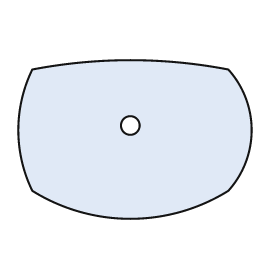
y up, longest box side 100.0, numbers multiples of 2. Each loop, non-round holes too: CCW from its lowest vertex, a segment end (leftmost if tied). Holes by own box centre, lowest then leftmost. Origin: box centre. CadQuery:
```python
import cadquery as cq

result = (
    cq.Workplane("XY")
    .moveTo(-44.0, -22.0)
    .threePointArc((-2.0, -34.0), (40.0, -22.0))
    .threePointArc((50.0, 4.0), (40.0, 30.0))
    .threePointArc((-2.0, 34.0), (-44.0, 30.0))
    .threePointArc((-50.0, 4.0), (-44.0, -22.0))
    .close()
    .moveTo(-2.0, 6.0)
    .circle(4.0)
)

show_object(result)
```